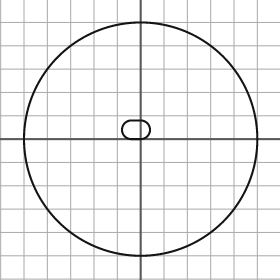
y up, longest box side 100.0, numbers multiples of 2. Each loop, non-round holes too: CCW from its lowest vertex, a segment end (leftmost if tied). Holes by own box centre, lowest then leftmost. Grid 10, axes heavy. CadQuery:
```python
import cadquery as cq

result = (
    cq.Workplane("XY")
    .moveTo(0.0, 0.0)
    .circle(50.0)
    .moveTo(-4.0, 0.0)
    .lineTo(0.0, 0.0)
    .threePointArc((4.0, 4.0), (0.0, 8.0))
    .lineTo(-4.0, 8.0)
    .threePointArc((-8.0, 4.0), (-4.0, 0.0))
    .close()
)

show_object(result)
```